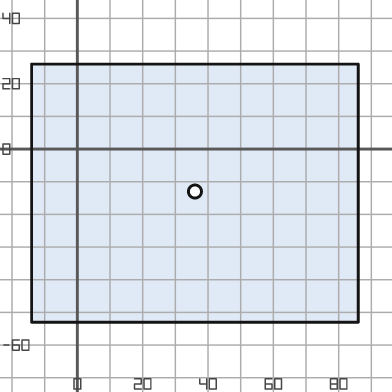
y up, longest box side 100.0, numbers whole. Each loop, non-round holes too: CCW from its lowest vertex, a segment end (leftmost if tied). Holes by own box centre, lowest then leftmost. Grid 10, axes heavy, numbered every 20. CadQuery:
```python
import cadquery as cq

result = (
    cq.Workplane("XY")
    .moveTo(-14.0, -53.0)
    .lineTo(86.0, -53.0)
    .lineTo(86.0, 26.0)
    .lineTo(-14.0, 26.0)
    .close()
    .moveTo(36.0, -13.0)
    .circle(2.0)
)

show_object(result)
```